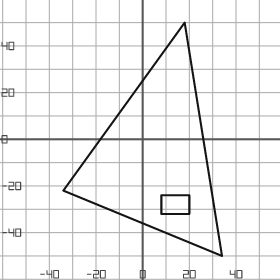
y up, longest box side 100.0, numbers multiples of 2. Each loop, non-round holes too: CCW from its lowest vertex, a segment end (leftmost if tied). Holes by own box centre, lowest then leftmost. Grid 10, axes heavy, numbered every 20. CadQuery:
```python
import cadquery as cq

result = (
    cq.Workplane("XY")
    .moveTo(34.0, -50.0)
    .lineTo(18.0, 50.0)
    .lineTo(-34.0, -22.0)
    .close()
    .moveTo(8.0, -32.0)
    .lineTo(20.0, -32.0)
    .lineTo(20.0, -24.0)
    .lineTo(8.0, -24.0)
    .close()
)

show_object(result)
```